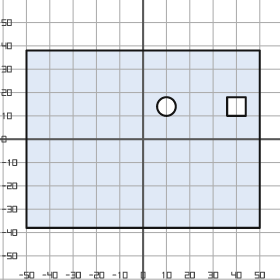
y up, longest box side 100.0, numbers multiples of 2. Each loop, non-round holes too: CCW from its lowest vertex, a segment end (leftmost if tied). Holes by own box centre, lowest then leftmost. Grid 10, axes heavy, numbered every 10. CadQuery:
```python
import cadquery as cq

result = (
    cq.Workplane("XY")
    .moveTo(-50.0, -38.0)
    .lineTo(50.0, -38.0)
    .lineTo(50.0, 38.0)
    .lineTo(-50.0, 38.0)
    .close()
    .moveTo(10.0, 14.0)
    .circle(4.0)
    .moveTo(36.0, 10.0)
    .lineTo(44.0, 10.0)
    .lineTo(44.0, 18.0)
    .lineTo(36.0, 18.0)
    .close()
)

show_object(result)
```